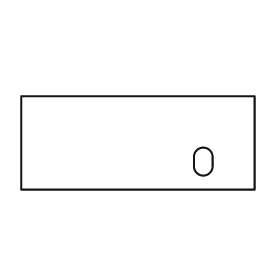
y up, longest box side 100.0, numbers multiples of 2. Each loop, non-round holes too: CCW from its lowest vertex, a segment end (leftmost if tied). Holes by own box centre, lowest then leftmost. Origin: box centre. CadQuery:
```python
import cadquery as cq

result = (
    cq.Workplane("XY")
    .moveTo(-50.0, -20.0)
    .lineTo(50.0, -20.0)
    .lineTo(50.0, 20.0)
    .lineTo(-50.0, 20.0)
    .close()
    .moveTo(24.0, -10.0)
    .threePointArc((28.0, -14.0), (32.0, -10.0))
    .lineTo(32.0, -6.0)
    .threePointArc((28.0, -2.0), (24.0, -6.0))
    .close()
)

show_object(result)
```